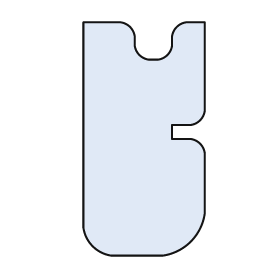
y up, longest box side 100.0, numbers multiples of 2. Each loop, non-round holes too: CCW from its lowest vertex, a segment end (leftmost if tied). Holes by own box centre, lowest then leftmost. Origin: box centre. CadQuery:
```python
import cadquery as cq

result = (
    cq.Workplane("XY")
    .moveTo(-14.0, -50.0)
    .lineTo(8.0, -50.0)
    .threePointArc((20.0, -44.0), (26.0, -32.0))
    .lineTo(26.0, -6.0)
    .threePointArc((24.0, -2.0), (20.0, 0.0))
    .lineTo(12.0, 0.0)
    .lineTo(12.0, 6.0)
    .lineTo(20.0, 6.0)
    .threePointArc((24.0, 8.0), (26.0, 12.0))
    .lineTo(26.0, 50.0)
    .lineTo(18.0, 50.0)
    .threePointArc((14.0, 48.0), (12.0, 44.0))
    .lineTo(12.0, 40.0)
    .threePointArc((10.0, 36.0), (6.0, 34.0))
    .lineTo(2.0, 34.0)
    .threePointArc((-2.0, 36.0), (-4.0, 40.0))
    .lineTo(-4.0, 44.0)
    .threePointArc((-6.0, 48.0), (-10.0, 50.0))
    .lineTo(-26.0, 50.0)
    .lineTo(-26.0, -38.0)
    .threePointArc((-22.0, -46.0), (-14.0, -50.0))
    .close()
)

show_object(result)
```